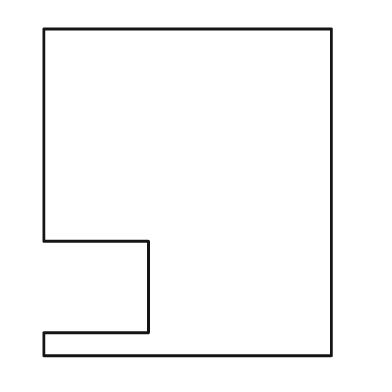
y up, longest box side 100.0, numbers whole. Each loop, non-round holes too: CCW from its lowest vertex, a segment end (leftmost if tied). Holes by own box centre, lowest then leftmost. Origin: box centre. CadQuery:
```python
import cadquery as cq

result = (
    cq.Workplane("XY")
    .moveTo(-44.0, -50.0)
    .lineTo(44.0, -50.0)
    .lineTo(44.0, 50.0)
    .lineTo(-44.0, 50.0)
    .lineTo(-44.0, -15.0)
    .lineTo(-12.0, -15.0)
    .lineTo(-12.0, -43.0)
    .lineTo(-44.0, -43.0)
    .close()
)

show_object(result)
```